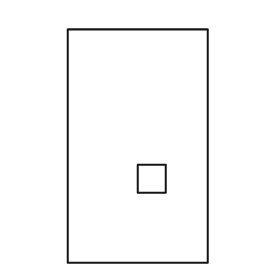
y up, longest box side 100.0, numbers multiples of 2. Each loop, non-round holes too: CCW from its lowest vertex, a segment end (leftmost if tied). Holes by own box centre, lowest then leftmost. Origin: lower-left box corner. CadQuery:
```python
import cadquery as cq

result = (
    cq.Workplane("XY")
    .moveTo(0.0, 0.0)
    .lineTo(60.0, 0.0)
    .lineTo(60.0, 100.0)
    .lineTo(0.0, 100.0)
    .close()
    .moveTo(30.0, 30.0)
    .lineTo(42.0, 30.0)
    .lineTo(42.0, 42.0)
    .lineTo(30.0, 42.0)
    .close()
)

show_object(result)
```